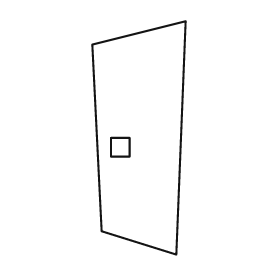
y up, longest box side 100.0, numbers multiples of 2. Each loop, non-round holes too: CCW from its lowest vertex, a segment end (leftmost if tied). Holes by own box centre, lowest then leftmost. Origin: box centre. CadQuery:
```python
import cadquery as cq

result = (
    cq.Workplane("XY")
    .moveTo(16.0, -50.0)
    .lineTo(20.0, 50.0)
    .lineTo(-20.0, 40.0)
    .lineTo(-16.0, -40.0)
    .close()
    .moveTo(-12.0, -8.0)
    .lineTo(-4.0, -8.0)
    .lineTo(-4.0, 0.0)
    .lineTo(-12.0, 0.0)
    .close()
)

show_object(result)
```